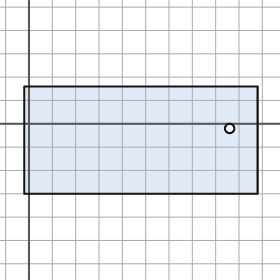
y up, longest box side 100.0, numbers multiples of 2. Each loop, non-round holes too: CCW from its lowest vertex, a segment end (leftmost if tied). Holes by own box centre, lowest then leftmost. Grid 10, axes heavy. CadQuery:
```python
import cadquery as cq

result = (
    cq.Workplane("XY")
    .moveTo(-2.0, -30.0)
    .lineTo(98.0, -30.0)
    .lineTo(98.0, 16.0)
    .lineTo(-2.0, 16.0)
    .close()
    .moveTo(86.0, -2.0)
    .circle(2.0)
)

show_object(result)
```